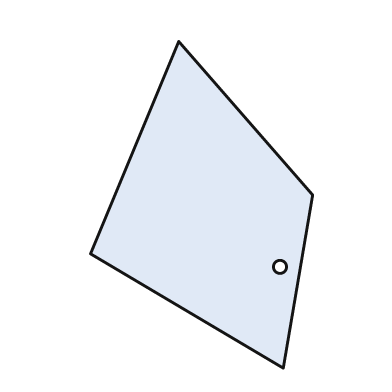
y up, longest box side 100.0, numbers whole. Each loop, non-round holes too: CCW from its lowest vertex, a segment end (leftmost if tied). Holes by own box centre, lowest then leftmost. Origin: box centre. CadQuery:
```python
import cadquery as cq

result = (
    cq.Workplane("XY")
    .moveTo(25.0, -50.0)
    .lineTo(34.0, 3.0)
    .lineTo(-7.0, 50.0)
    .lineTo(-34.0, -15.0)
    .close()
    .moveTo(24.0, -19.0)
    .circle(2.0)
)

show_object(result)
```